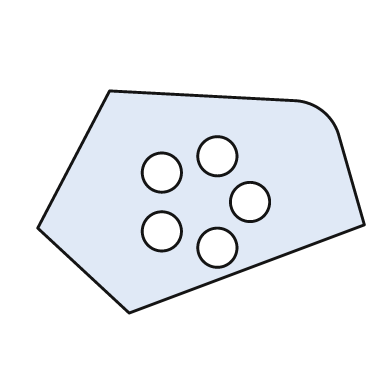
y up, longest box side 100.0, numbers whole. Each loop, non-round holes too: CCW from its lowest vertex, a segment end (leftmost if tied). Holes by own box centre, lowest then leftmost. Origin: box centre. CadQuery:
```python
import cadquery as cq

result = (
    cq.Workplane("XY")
    .moveTo(-22.0, -34.0)
    .lineTo(50.0, -7.0)
    .lineTo(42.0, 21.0)
    .threePointArc((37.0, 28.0), (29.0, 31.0))
    .lineTo(-28.0, 34.0)
    .lineTo(-50.0, -8.0)
    .close()
    .moveTo(5.0, -14.0)
    .circle(6.0)
    .moveTo(-12.0, -9.0)
    .circle(6.0)
    .moveTo(15.0, 0.0)
    .circle(6.0)
    .moveTo(-12.0, 9.0)
    .circle(6.0)
    .moveTo(5.0, 14.0)
    .circle(6.0)
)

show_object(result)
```